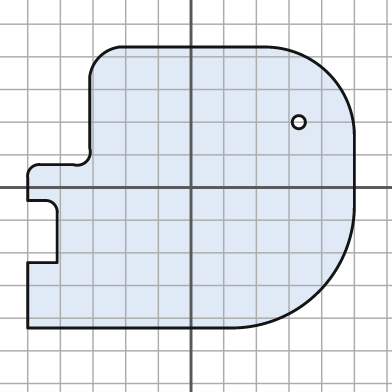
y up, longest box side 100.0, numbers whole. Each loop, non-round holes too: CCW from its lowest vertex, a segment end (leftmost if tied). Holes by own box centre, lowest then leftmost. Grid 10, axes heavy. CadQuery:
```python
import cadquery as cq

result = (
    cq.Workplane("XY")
    .moveTo(-50.0, -43.0)
    .lineTo(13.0, -43.0)
    .threePointArc((39.0, -32.0), (50.0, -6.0))
    .lineTo(50.0, 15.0)
    .threePointArc((42.0, 35.0), (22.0, 43.0))
    .lineTo(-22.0, 43.0)
    .threePointArc((-28.0, 40.0), (-31.0, 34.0))
    .lineTo(-31.0, 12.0)
    .threePointArc((-32.0, 8.0), (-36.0, 7.0))
    .lineTo(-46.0, 7.0)
    .threePointArc((-49.0, 6.0), (-50.0, 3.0))
    .lineTo(-50.0, -4.0)
    .lineTo(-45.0, -4.0)
    .threePointArc((-42.0, -5.0), (-41.0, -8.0))
    .lineTo(-41.0, -23.0)
    .lineTo(-50.0, -23.0)
    .close()
    .moveTo(33.0, 20.0)
    .circle(2.0)
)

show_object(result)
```